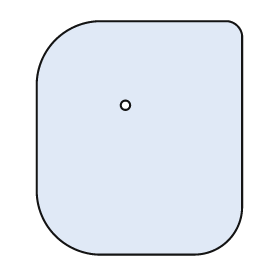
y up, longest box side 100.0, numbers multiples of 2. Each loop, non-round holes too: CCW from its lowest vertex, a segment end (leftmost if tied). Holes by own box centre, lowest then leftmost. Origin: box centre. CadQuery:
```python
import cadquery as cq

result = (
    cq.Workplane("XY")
    .moveTo(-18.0, -50.0)
    .lineTo(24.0, -50.0)
    .threePointArc((38.0, -44.0), (44.0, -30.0))
    .lineTo(44.0, 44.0)
    .threePointArc((42.0, 48.0), (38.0, 50.0))
    .lineTo(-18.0, 50.0)
    .threePointArc((-36.0, 42.0), (-44.0, 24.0))
    .lineTo(-44.0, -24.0)
    .threePointArc((-36.0, -42.0), (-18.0, -50.0))
    .close()
    .moveTo(-6.0, 14.0)
    .circle(2.0)
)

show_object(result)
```